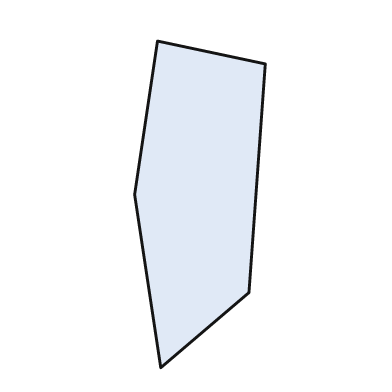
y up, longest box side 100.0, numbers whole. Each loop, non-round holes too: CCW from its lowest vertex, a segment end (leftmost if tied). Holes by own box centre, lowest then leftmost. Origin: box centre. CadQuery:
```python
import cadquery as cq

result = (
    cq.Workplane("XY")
    .moveTo(-12.0, -50.0)
    .lineTo(15.0, -27.0)
    .lineTo(20.0, 43.0)
    .lineTo(-13.0, 50.0)
    .lineTo(-20.0, 3.0)
    .close()
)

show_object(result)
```